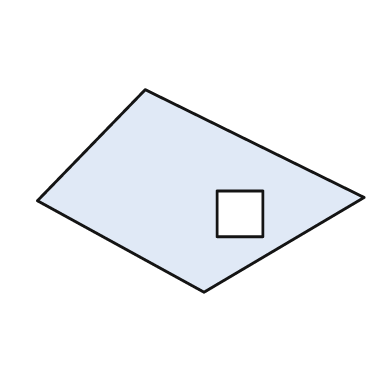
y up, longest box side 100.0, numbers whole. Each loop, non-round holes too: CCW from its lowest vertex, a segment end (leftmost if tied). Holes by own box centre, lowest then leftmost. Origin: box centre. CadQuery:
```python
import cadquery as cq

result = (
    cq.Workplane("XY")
    .moveTo(1.0, -31.0)
    .lineTo(50.0, -2.0)
    .lineTo(-17.0, 31.0)
    .lineTo(-50.0, -3.0)
    .close()
    .moveTo(5.0, -14.0)
    .lineTo(19.0, -14.0)
    .lineTo(19.0, 0.0)
    .lineTo(5.0, 0.0)
    .close()
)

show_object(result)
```